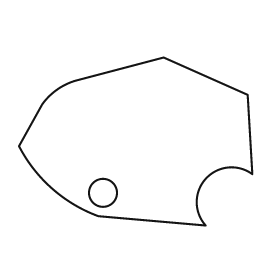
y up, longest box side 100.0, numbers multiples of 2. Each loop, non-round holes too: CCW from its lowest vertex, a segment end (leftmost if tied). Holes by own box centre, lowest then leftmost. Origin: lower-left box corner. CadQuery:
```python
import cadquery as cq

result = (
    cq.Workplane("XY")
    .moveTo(80.0, 0.0)
    .threePointArc((80.0, 20.0), (100.0, 22.0))
    .lineTo(98.0, 56.0)
    .lineTo(62.0, 72.0)
    .lineTo(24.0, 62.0)
    .threePointArc((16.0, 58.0), (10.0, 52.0))
    .lineTo(0.0, 34.0)
    .threePointArc((14.0, 16.0), (34.0, 4.0))
    .close()
    .moveTo(36.0, 14.0)
    .circle(6.0)
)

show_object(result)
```